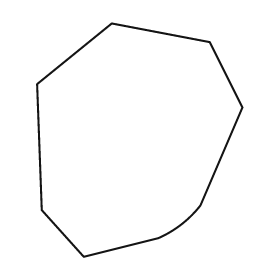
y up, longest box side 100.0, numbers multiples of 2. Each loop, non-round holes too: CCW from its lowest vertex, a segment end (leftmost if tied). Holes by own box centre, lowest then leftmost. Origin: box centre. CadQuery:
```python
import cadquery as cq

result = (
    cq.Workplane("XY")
    .moveTo(-24.0, -50.0)
    .lineTo(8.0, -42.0)
    .threePointArc((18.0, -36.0), (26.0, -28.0))
    .lineTo(44.0, 14.0)
    .lineTo(30.0, 42.0)
    .lineTo(-12.0, 50.0)
    .lineTo(-44.0, 24.0)
    .lineTo(-42.0, -30.0)
    .close()
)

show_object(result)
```